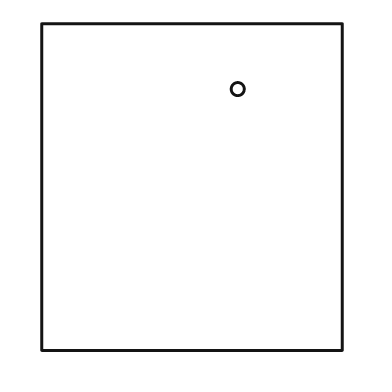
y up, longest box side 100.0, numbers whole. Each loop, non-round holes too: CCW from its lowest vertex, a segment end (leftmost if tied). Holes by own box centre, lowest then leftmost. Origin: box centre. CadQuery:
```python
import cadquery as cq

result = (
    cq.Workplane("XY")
    .moveTo(-46.0, -50.0)
    .lineTo(46.0, -50.0)
    .lineTo(46.0, 50.0)
    .lineTo(-46.0, 50.0)
    .close()
    .moveTo(14.0, 30.0)
    .circle(2.0)
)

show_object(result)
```